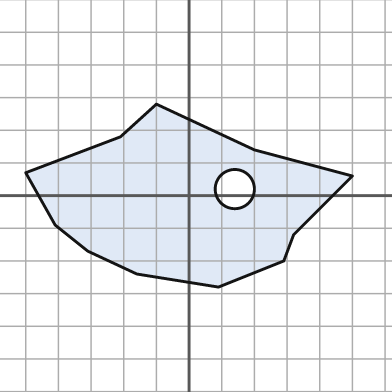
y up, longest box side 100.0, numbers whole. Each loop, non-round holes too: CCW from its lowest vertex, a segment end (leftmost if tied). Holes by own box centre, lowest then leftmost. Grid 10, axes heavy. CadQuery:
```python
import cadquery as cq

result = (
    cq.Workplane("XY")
    .moveTo(9.0, -28.0)
    .lineTo(29.0, -20.0)
    .lineTo(32.0, -12.0)
    .lineTo(50.0, 6.0)
    .lineTo(20.0, 14.0)
    .lineTo(-10.0, 28.0)
    .lineTo(-21.0, 18.0)
    .lineTo(-50.0, 7.0)
    .lineTo(-41.0, -9.0)
    .lineTo(-31.0, -17.0)
    .lineTo(-16.0, -24.0)
    .close()
    .moveTo(14.0, 2.0)
    .circle(6.0)
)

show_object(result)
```